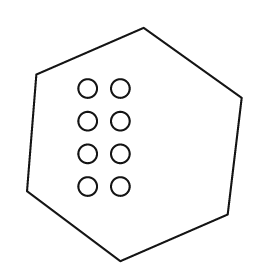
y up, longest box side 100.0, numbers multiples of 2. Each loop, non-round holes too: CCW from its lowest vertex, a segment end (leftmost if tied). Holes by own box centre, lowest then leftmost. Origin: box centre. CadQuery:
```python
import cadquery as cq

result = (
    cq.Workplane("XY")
    .moveTo(-6.0, -50.0)
    .lineTo(40.0, -30.0)
    .lineTo(46.0, 20.0)
    .lineTo(4.0, 50.0)
    .lineTo(-42.0, 30.0)
    .lineTo(-46.0, -20.0)
    .close()
    .moveTo(-20.0, -18.0)
    .circle(4.0)
    .moveTo(-6.0, -18.0)
    .circle(4.0)
    .moveTo(-20.0, -4.0)
    .circle(4.0)
    .moveTo(-6.0, -4.0)
    .circle(4.0)
    .moveTo(-20.0, 10.0)
    .circle(4.0)
    .moveTo(-6.0, 10.0)
    .circle(4.0)
    .moveTo(-20.0, 24.0)
    .circle(4.0)
    .moveTo(-6.0, 24.0)
    .circle(4.0)
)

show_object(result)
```